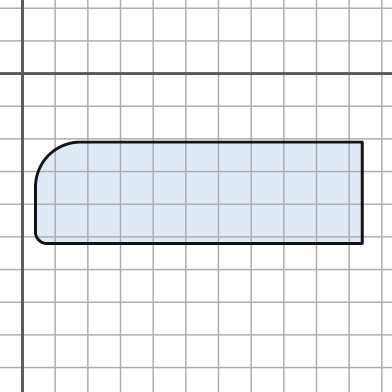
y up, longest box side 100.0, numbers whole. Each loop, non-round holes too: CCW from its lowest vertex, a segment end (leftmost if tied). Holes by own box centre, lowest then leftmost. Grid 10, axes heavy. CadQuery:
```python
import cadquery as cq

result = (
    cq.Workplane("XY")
    .moveTo(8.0, -52.0)
    .lineTo(104.0, -52.0)
    .lineTo(104.0, -21.0)
    .lineTo(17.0, -21.0)
    .threePointArc((8.0, -25.0), (4.0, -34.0))
    .lineTo(4.0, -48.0)
    .threePointArc((5.0, -51.0), (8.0, -52.0))
    .close()
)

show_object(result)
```